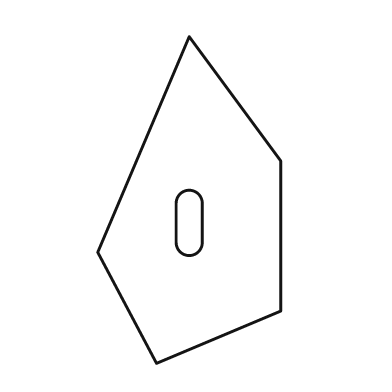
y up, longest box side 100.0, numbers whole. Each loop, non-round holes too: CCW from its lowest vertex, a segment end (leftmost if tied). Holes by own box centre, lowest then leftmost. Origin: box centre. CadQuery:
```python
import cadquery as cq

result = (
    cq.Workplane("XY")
    .moveTo(-10.0, -50.0)
    .lineTo(28.0, -34.0)
    .lineTo(28.0, 12.0)
    .lineTo(0.0, 50.0)
    .lineTo(-28.0, -16.0)
    .close()
    .moveTo(-4.0, -13.0)
    .threePointArc((0.0, -17.0), (4.0, -13.0))
    .lineTo(4.0, -1.0)
    .threePointArc((0.0, 3.0), (-4.0, -1.0))
    .close()
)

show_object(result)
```